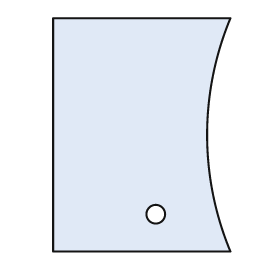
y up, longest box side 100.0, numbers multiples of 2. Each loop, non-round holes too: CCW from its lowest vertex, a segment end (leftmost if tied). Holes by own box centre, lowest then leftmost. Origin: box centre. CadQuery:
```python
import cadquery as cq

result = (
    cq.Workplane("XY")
    .moveTo(-38.0, -50.0)
    .lineTo(38.0, -50.0)
    .threePointArc((28.0, 0.0), (38.0, 50.0))
    .lineTo(-38.0, 50.0)
    .close()
    .moveTo(6.0, -34.0)
    .circle(4.0)
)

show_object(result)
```